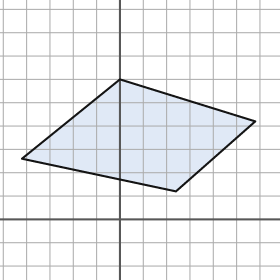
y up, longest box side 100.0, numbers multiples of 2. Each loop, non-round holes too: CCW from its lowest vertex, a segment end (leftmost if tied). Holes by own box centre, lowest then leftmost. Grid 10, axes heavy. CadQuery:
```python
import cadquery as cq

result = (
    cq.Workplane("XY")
    .moveTo(24.0, 12.0)
    .lineTo(58.0, 42.0)
    .lineTo(0.0, 60.0)
    .lineTo(-42.0, 26.0)
    .close()
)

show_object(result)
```